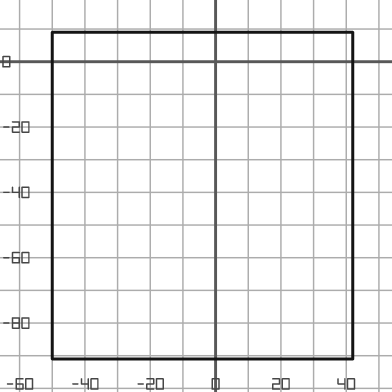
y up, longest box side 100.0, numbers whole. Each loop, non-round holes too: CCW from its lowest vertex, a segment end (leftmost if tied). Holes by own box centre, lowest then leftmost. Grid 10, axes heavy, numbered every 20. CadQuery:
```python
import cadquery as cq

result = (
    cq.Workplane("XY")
    .moveTo(-50.0, -91.0)
    .lineTo(42.0, -91.0)
    .lineTo(42.0, 9.0)
    .lineTo(-50.0, 9.0)
    .close()
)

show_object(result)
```